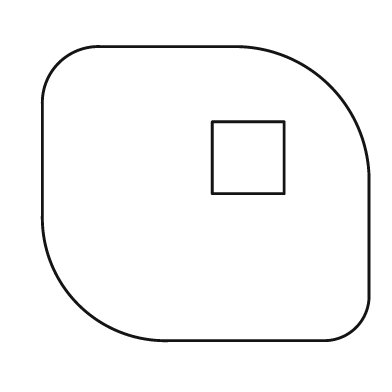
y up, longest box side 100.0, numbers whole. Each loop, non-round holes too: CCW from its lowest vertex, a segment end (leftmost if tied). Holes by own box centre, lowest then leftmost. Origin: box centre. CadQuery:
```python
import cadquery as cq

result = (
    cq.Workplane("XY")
    .moveTo(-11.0, -45.0)
    .lineTo(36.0, -45.0)
    .threePointArc((46.0, -41.0), (50.0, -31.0))
    .lineTo(50.0, 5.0)
    .threePointArc((38.0, 33.0), (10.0, 45.0))
    .lineTo(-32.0, 45.0)
    .threePointArc((-45.0, 40.0), (-50.0, 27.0))
    .lineTo(-50.0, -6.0)
    .threePointArc((-39.0, -34.0), (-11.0, -45.0))
    .close()
    .moveTo(2.0, 0.0)
    .lineTo(24.0, 0.0)
    .lineTo(24.0, 22.0)
    .lineTo(2.0, 22.0)
    .close()
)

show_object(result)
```